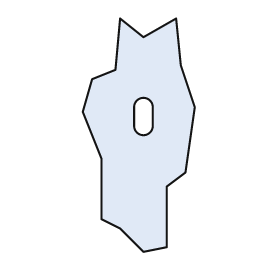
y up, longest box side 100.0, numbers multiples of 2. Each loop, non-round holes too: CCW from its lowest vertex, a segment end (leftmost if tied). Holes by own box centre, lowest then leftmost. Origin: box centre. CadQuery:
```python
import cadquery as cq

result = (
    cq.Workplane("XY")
    .moveTo(2.0, -50.0)
    .lineTo(12.0, -48.0)
    .lineTo(12.0, -22.0)
    .lineTo(20.0, -16.0)
    .lineTo(24.0, 12.0)
    .lineTo(18.0, 30.0)
    .lineTo(16.0, 50.0)
    .lineTo(2.0, 42.0)
    .lineTo(-8.0, 50.0)
    .lineTo(-10.0, 28.0)
    .lineTo(-20.0, 24.0)
    .lineTo(-24.0, 10.0)
    .lineTo(-16.0, -10.0)
    .lineTo(-16.0, -36.0)
    .lineTo(-8.0, -40.0)
    .close()
    .moveTo(-2.0, 4.0)
    .threePointArc((2.0, 0.0), (6.0, 4.0))
    .lineTo(6.0, 12.0)
    .threePointArc((2.0, 16.0), (-2.0, 12.0))
    .close()
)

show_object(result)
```